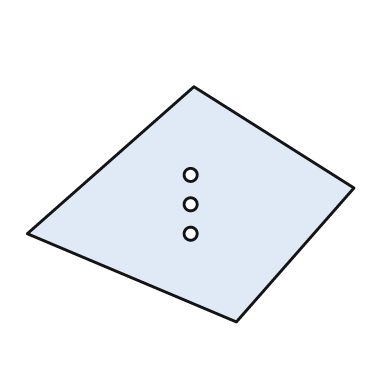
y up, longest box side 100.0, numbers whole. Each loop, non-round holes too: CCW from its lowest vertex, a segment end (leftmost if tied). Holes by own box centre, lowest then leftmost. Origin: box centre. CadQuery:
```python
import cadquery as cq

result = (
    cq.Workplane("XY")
    .moveTo(14.0, -36.0)
    .lineTo(50.0, 5.0)
    .lineTo(1.0, 36.0)
    .lineTo(-50.0, -9.0)
    .close()
    .moveTo(0.0, -9.0)
    .circle(2.0)
    .moveTo(0.0, 0.0)
    .circle(2.0)
    .moveTo(0.0, 9.0)
    .circle(2.0)
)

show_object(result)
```